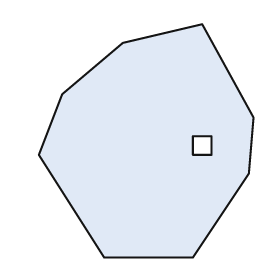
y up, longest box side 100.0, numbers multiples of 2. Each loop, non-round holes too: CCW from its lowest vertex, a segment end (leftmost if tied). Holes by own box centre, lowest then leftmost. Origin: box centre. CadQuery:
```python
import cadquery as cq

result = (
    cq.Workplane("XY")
    .moveTo(-18.0, -50.0)
    .lineTo(20.0, -50.0)
    .lineTo(44.0, -14.0)
    .lineTo(46.0, 10.0)
    .lineTo(24.0, 50.0)
    .lineTo(-10.0, 42.0)
    .lineTo(-36.0, 20.0)
    .lineTo(-46.0, -6.0)
    .close()
    .moveTo(20.0, -6.0)
    .lineTo(28.0, -6.0)
    .lineTo(28.0, 2.0)
    .lineTo(20.0, 2.0)
    .close()
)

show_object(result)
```